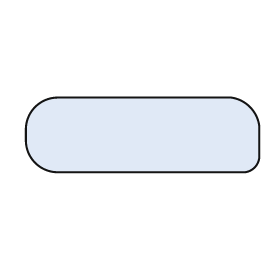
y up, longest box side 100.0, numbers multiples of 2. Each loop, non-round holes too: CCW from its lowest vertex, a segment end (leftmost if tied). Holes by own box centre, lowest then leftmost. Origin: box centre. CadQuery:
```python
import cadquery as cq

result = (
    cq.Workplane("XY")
    .moveTo(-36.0, -16.0)
    .lineTo(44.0, -16.0)
    .threePointArc((48.0, -14.0), (50.0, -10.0))
    .lineTo(50.0, 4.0)
    .threePointArc((46.0, 12.0), (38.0, 16.0))
    .lineTo(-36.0, 16.0)
    .threePointArc((-46.0, 12.0), (-50.0, 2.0))
    .lineTo(-50.0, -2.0)
    .threePointArc((-46.0, -12.0), (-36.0, -16.0))
    .close()
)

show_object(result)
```